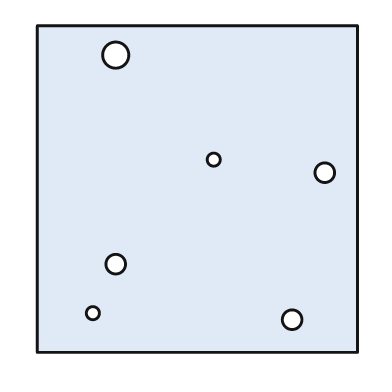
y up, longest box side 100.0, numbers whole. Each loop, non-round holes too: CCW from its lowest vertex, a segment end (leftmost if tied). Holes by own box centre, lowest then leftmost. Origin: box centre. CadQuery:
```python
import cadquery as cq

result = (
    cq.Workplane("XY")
    .moveTo(-49.0, -50.0)
    .lineTo(49.0, -50.0)
    .lineTo(49.0, 50.0)
    .lineTo(-49.0, 50.0)
    .close()
    .moveTo(29.0, -40.0)
    .circle(3.0)
    .moveTo(-32.0, -38.0)
    .circle(2.0)
    .moveTo(-25.0, -23.0)
    .circle(3.0)
    .moveTo(39.0, 5.0)
    .circle(3.0)
    .moveTo(5.0, 9.0)
    .circle(2.0)
    .moveTo(-25.0, 41.0)
    .circle(4.0)
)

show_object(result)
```